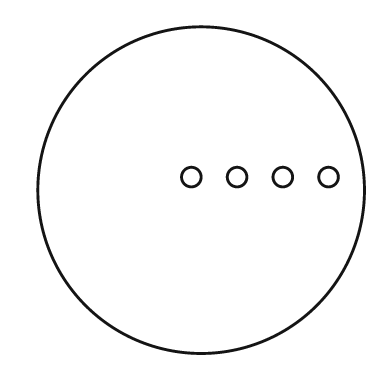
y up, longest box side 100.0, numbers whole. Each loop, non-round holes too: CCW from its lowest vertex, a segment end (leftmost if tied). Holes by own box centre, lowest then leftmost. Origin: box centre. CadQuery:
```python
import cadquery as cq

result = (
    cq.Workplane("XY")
    .moveTo(0.0, 0.0)
    .circle(50.0)
    .moveTo(-3.0, 4.0)
    .circle(3.0)
    .moveTo(11.0, 4.0)
    .circle(3.0)
    .moveTo(25.0, 4.0)
    .circle(3.0)
    .moveTo(39.0, 4.0)
    .circle(3.0)
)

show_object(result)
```